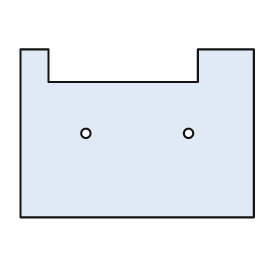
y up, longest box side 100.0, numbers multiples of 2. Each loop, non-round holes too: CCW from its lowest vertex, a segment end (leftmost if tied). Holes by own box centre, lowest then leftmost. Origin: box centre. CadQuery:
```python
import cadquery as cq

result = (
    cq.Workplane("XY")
    .moveTo(-50.0, -36.0)
    .lineTo(50.0, -36.0)
    .lineTo(50.0, 36.0)
    .lineTo(26.0, 36.0)
    .lineTo(26.0, 22.0)
    .lineTo(-38.0, 22.0)
    .lineTo(-38.0, 36.0)
    .lineTo(-50.0, 36.0)
    .close()
    .moveTo(-22.0, 0.0)
    .circle(2.0)
    .moveTo(22.0, 0.0)
    .circle(2.0)
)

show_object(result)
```